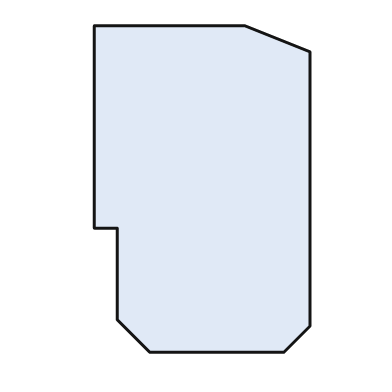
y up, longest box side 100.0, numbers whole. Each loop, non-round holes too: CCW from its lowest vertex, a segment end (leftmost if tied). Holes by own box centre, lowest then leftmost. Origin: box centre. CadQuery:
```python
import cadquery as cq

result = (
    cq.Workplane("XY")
    .moveTo(-16.0, -50.0)
    .lineTo(25.0, -50.0)
    .lineTo(33.0, -42.0)
    .lineTo(33.0, 42.0)
    .lineTo(13.0, 50.0)
    .lineTo(-33.0, 50.0)
    .lineTo(-33.0, -12.0)
    .lineTo(-26.0, -12.0)
    .lineTo(-26.0, -40.0)
    .close()
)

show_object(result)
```